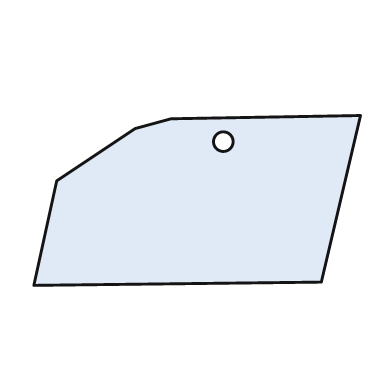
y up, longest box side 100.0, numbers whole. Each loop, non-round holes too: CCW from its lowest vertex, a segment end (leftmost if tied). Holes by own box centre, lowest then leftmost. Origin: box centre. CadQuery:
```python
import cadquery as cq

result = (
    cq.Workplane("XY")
    .moveTo(-50.0, -26.0)
    .lineTo(38.0, -25.0)
    .lineTo(50.0, 26.0)
    .lineTo(-8.0, 25.0)
    .lineTo(-19.0, 22.0)
    .lineTo(-43.0, 6.0)
    .close()
    .moveTo(8.0, 18.0)
    .circle(3.0)
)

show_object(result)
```